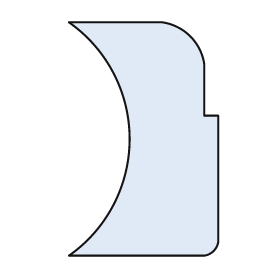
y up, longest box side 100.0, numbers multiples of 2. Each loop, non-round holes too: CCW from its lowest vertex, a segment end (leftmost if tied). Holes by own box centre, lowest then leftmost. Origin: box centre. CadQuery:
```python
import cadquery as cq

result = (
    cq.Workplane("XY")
    .moveTo(-32.0, -50.0)
    .lineTo(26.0, -50.0)
    .threePointArc((30.0, -48.0), (32.0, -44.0))
    .lineTo(32.0, 10.0)
    .lineTo(26.0, 10.0)
    .lineTo(26.0, 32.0)
    .threePointArc((20.0, 44.0), (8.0, 50.0))
    .lineTo(-32.0, 50.0)
    .threePointArc((-6.0, 0.0), (-32.0, -50.0))
    .close()
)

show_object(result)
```